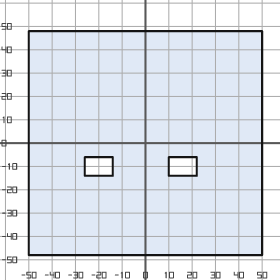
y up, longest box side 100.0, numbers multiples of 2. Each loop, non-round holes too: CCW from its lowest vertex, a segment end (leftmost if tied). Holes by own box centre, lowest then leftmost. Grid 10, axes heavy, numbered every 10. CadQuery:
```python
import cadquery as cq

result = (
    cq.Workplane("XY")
    .moveTo(-50.0, -48.0)
    .lineTo(50.0, -48.0)
    .lineTo(50.0, 48.0)
    .lineTo(-50.0, 48.0)
    .close()
    .moveTo(-26.0, -14.0)
    .lineTo(-14.0, -14.0)
    .lineTo(-14.0, -6.0)
    .lineTo(-26.0, -6.0)
    .close()
    .moveTo(10.0, -14.0)
    .lineTo(22.0, -14.0)
    .lineTo(22.0, -6.0)
    .lineTo(10.0, -6.0)
    .close()
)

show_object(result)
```